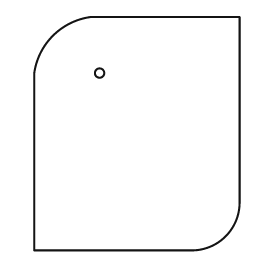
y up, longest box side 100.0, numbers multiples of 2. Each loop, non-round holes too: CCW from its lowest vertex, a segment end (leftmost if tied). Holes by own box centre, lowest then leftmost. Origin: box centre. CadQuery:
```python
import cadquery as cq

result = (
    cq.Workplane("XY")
    .moveTo(-44.0, -50.0)
    .lineTo(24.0, -50.0)
    .threePointArc((38.0, -44.0), (44.0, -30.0))
    .lineTo(44.0, 50.0)
    .lineTo(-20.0, 50.0)
    .threePointArc((-36.0, 42.0), (-44.0, 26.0))
    .close()
    .moveTo(-16.0, 26.0)
    .circle(2.0)
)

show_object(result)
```